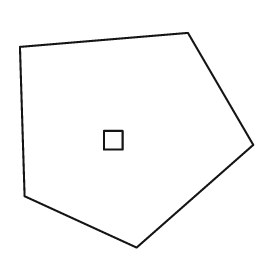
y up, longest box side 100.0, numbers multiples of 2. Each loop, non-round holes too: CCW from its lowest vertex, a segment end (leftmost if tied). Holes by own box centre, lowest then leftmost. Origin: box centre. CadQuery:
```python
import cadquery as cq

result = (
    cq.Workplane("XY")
    .moveTo(0.0, -46.0)
    .lineTo(50.0, -2.0)
    .lineTo(22.0, 46.0)
    .lineTo(-50.0, 40.0)
    .lineTo(-48.0, -24.0)
    .close()
    .moveTo(-14.0, -4.0)
    .lineTo(-6.0, -4.0)
    .lineTo(-6.0, 4.0)
    .lineTo(-14.0, 4.0)
    .close()
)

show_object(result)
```